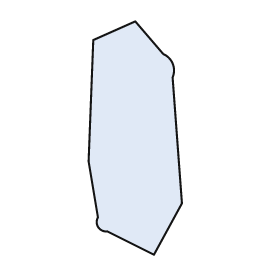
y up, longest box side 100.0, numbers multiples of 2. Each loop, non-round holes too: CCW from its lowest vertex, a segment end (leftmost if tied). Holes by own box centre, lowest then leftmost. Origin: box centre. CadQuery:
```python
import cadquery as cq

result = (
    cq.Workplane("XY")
    .moveTo(8.0, -50.0)
    .lineTo(20.0, -28.0)
    .lineTo(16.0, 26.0)
    .threePointArc((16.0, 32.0), (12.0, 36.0))
    .lineTo(0.0, 50.0)
    .lineTo(-18.0, 42.0)
    .lineTo(-20.0, -10.0)
    .lineTo(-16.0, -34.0)
    .threePointArc((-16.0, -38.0), (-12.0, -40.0))
    .close()
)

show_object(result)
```